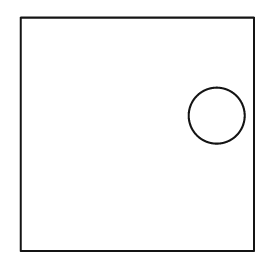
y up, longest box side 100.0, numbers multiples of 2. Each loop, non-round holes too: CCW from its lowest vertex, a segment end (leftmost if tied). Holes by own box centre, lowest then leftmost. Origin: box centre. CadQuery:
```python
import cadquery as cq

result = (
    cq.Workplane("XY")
    .moveTo(-50.0, -50.0)
    .lineTo(50.0, -50.0)
    .lineTo(50.0, 50.0)
    .lineTo(-50.0, 50.0)
    .close()
    .moveTo(34.0, 8.0)
    .circle(12.0)
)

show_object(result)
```